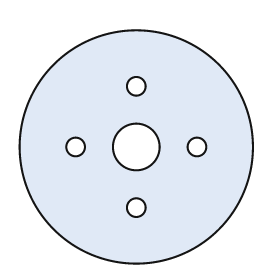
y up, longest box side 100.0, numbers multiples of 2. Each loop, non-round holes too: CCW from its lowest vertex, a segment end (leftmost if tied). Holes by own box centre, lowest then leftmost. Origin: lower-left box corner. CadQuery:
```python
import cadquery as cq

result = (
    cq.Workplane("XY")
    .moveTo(50.0, 50.0)
    .circle(50.0)
    .moveTo(50.0, 24.0)
    .circle(4.0)
    .moveTo(24.0, 50.0)
    .circle(4.0)
    .moveTo(50.0, 50.0)
    .circle(10.0)
    .moveTo(76.0, 50.0)
    .circle(4.0)
    .moveTo(50.0, 76.0)
    .circle(4.0)
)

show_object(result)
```